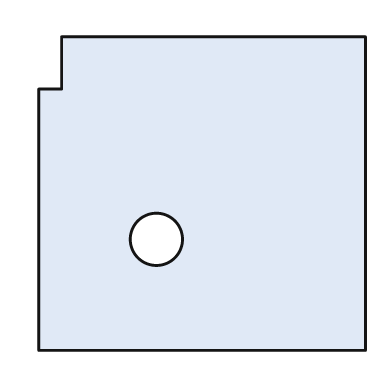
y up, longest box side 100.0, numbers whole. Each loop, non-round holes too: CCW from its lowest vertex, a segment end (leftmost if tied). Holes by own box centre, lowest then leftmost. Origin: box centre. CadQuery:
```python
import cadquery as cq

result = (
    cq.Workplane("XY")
    .moveTo(-50.0, -48.0)
    .lineTo(50.0, -48.0)
    .lineTo(50.0, 48.0)
    .lineTo(-43.0, 48.0)
    .lineTo(-43.0, 32.0)
    .lineTo(-50.0, 32.0)
    .close()
    .moveTo(-14.0, -14.0)
    .circle(8.0)
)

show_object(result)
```